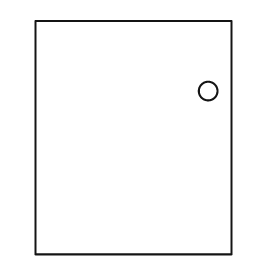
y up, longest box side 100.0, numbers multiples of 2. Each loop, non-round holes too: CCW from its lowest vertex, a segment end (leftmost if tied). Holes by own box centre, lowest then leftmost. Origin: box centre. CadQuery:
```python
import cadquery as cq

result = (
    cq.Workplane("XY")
    .moveTo(-42.0, -50.0)
    .lineTo(42.0, -50.0)
    .lineTo(42.0, 50.0)
    .lineTo(-42.0, 50.0)
    .close()
    .moveTo(32.0, 20.0)
    .circle(4.0)
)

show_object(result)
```